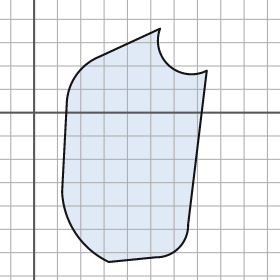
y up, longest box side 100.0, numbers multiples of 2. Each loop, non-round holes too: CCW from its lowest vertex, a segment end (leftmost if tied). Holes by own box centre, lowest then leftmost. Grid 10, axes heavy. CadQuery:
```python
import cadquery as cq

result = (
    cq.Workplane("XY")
    .moveTo(32.0, -64.0)
    .lineTo(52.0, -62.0)
    .threePointArc((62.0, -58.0), (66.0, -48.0))
    .lineTo(74.0, 18.0)
    .threePointArc((58.0, 20.0), (54.0, 36.0))
    .lineTo(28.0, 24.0)
    .threePointArc((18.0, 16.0), (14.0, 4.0))
    .lineTo(12.0, -34.0)
    .threePointArc((18.0, -52.0), (32.0, -64.0))
    .close()
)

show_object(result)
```